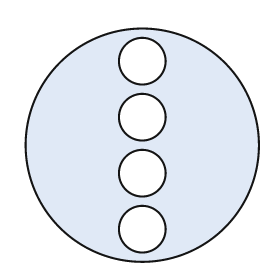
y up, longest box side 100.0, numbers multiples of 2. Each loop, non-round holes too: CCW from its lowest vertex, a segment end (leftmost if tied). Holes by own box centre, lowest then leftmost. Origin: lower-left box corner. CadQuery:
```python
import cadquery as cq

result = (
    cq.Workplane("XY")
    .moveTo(50.0, 50.0)
    .circle(50.0)
    .moveTo(50.0, 14.0)
    .circle(10.0)
    .moveTo(50.0, 38.0)
    .circle(10.0)
    .moveTo(50.0, 62.0)
    .circle(10.0)
    .moveTo(50.0, 86.0)
    .circle(10.0)
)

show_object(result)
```